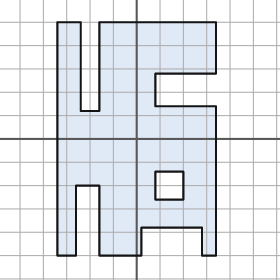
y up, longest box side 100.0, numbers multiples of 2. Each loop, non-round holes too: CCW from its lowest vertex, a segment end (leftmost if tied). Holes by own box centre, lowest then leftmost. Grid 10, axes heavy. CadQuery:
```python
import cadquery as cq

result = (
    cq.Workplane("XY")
    .moveTo(-34.0, -50.0)
    .lineTo(-26.0, -50.0)
    .lineTo(-26.0, -20.0)
    .lineTo(-16.0, -20.0)
    .lineTo(-16.0, -50.0)
    .lineTo(2.0, -50.0)
    .lineTo(2.0, -38.0)
    .lineTo(28.0, -38.0)
    .lineTo(28.0, -50.0)
    .lineTo(34.0, -50.0)
    .lineTo(34.0, 14.0)
    .lineTo(8.0, 14.0)
    .lineTo(8.0, 28.0)
    .lineTo(34.0, 28.0)
    .lineTo(34.0, 50.0)
    .lineTo(-16.0, 50.0)
    .lineTo(-16.0, 12.0)
    .lineTo(-24.0, 12.0)
    .lineTo(-24.0, 50.0)
    .lineTo(-34.0, 50.0)
    .close()
    .moveTo(8.0, -26.0)
    .lineTo(20.0, -26.0)
    .lineTo(20.0, -14.0)
    .lineTo(8.0, -14.0)
    .close()
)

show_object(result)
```